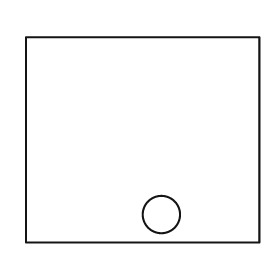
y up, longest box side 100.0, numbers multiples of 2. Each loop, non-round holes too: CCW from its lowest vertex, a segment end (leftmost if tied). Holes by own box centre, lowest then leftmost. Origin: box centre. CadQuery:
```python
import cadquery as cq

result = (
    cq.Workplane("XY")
    .moveTo(-50.0, -44.0)
    .lineTo(50.0, -44.0)
    .lineTo(50.0, 44.0)
    .lineTo(-50.0, 44.0)
    .close()
    .moveTo(8.0, -32.0)
    .circle(8.0)
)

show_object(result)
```